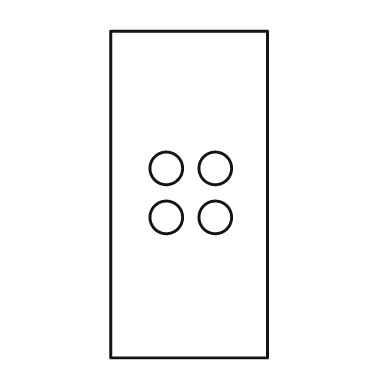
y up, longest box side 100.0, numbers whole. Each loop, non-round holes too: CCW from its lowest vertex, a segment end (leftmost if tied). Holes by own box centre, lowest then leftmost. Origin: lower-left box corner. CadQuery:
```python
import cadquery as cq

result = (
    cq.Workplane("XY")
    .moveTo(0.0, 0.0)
    .lineTo(48.0, 0.0)
    .lineTo(48.0, 100.0)
    .lineTo(0.0, 100.0)
    .close()
    .moveTo(17.0, 43.0)
    .circle(5.0)
    .moveTo(32.0, 43.0)
    .circle(5.0)
    .moveTo(17.0, 58.0)
    .circle(5.0)
    .moveTo(32.0, 58.0)
    .circle(5.0)
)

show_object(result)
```